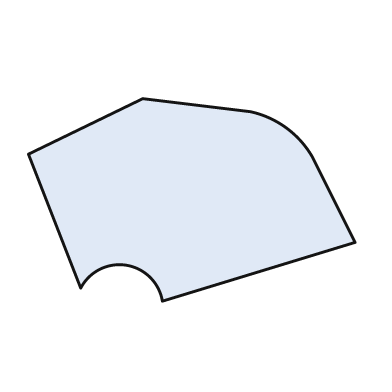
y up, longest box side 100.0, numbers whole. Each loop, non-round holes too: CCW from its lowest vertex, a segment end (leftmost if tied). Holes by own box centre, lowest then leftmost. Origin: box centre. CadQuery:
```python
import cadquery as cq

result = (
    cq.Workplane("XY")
    .moveTo(-9.0, -31.0)
    .lineTo(50.0, -13.0)
    .lineTo(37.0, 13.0)
    .threePointArc((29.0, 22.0), (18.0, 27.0))
    .lineTo(-15.0, 31.0)
    .lineTo(-50.0, 14.0)
    .lineTo(-34.0, -27.0)
    .threePointArc((-20.0, -20.0), (-9.0, -31.0))
    .close()
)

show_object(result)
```